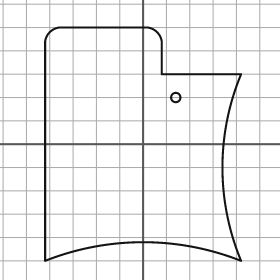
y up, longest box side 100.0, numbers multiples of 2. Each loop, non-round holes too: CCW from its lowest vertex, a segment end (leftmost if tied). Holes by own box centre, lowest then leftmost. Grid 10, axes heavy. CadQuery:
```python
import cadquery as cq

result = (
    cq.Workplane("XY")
    .moveTo(-42.0, -50.0)
    .threePointArc((0.0, -42.0), (42.0, -50.0))
    .threePointArc((34.0, -10.0), (42.0, 30.0))
    .lineTo(8.0, 30.0)
    .lineTo(8.0, 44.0)
    .threePointArc((6.0, 48.0), (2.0, 50.0))
    .lineTo(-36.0, 50.0)
    .threePointArc((-40.0, 48.0), (-42.0, 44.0))
    .close()
    .moveTo(14.0, 20.0)
    .circle(2.0)
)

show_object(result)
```